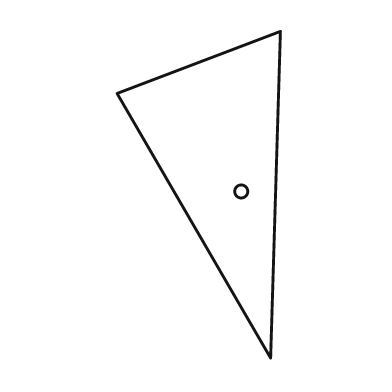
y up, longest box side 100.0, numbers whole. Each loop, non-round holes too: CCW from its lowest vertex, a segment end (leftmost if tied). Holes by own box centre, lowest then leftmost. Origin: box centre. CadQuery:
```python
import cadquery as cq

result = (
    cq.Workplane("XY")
    .moveTo(22.0, -50.0)
    .lineTo(25.0, 50.0)
    .lineTo(-25.0, 31.0)
    .close()
    .moveTo(13.0, 1.0)
    .circle(2.0)
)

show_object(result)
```